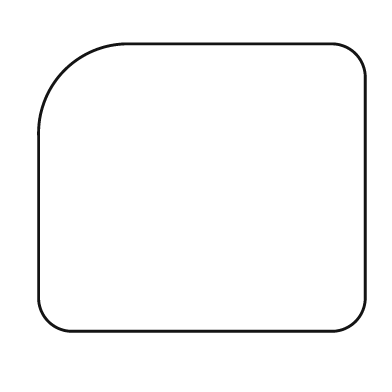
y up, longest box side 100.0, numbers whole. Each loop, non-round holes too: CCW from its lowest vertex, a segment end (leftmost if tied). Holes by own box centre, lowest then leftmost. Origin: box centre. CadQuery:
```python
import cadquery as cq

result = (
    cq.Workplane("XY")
    .moveTo(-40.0, -44.0)
    .lineTo(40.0, -44.0)
    .threePointArc((47.0, -41.0), (50.0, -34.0))
    .lineTo(50.0, 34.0)
    .threePointArc((47.0, 41.0), (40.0, 44.0))
    .lineTo(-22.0, 44.0)
    .threePointArc((-42.0, 36.0), (-50.0, 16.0))
    .lineTo(-50.0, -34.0)
    .threePointArc((-47.0, -41.0), (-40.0, -44.0))
    .close()
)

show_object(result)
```